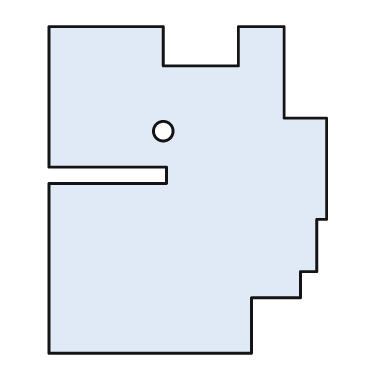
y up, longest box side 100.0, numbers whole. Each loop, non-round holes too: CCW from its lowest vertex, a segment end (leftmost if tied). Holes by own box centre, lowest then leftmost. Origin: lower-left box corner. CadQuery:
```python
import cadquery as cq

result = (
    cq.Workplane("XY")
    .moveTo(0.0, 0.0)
    .lineTo(62.0, 0.0)
    .lineTo(62.0, 17.0)
    .lineTo(77.0, 17.0)
    .lineTo(77.0, 25.0)
    .lineTo(82.0, 25.0)
    .lineTo(82.0, 41.0)
    .lineTo(85.0, 41.0)
    .lineTo(85.0, 72.0)
    .lineTo(72.0, 72.0)
    .lineTo(72.0, 100.0)
    .lineTo(58.0, 100.0)
    .lineTo(58.0, 88.0)
    .lineTo(35.0, 88.0)
    .lineTo(35.0, 100.0)
    .lineTo(0.0, 100.0)
    .lineTo(0.0, 57.0)
    .lineTo(36.0, 57.0)
    .lineTo(36.0, 52.0)
    .lineTo(0.0, 52.0)
    .close()
    .moveTo(35.0, 68.0)
    .circle(3.0)
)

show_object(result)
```